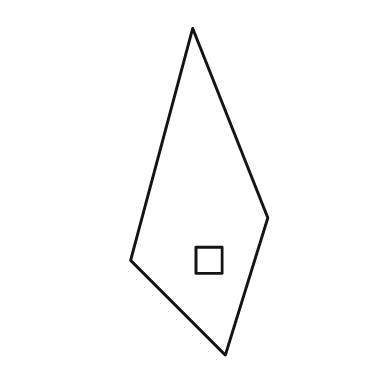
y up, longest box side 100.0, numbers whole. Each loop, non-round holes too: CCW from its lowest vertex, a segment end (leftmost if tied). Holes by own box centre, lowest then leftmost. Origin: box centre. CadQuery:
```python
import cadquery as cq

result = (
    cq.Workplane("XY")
    .moveTo(8.0, -50.0)
    .lineTo(21.0, -8.0)
    .lineTo(-2.0, 50.0)
    .lineTo(-21.0, -21.0)
    .close()
    .moveTo(-1.0, -25.0)
    .lineTo(7.0, -25.0)
    .lineTo(7.0, -17.0)
    .lineTo(-1.0, -17.0)
    .close()
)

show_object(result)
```